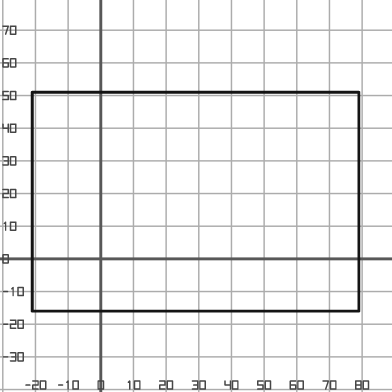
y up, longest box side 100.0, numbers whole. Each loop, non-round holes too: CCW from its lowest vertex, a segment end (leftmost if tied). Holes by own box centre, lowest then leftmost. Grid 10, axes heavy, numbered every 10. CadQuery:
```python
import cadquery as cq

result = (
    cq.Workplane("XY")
    .moveTo(-21.0, -16.0)
    .lineTo(79.0, -16.0)
    .lineTo(79.0, 51.0)
    .lineTo(-21.0, 51.0)
    .close()
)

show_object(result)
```